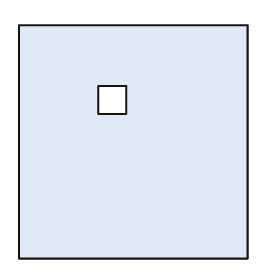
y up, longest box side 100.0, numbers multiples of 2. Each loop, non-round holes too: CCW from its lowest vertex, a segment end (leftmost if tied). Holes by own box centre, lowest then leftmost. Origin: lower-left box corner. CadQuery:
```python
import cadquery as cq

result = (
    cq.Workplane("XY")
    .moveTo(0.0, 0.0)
    .lineTo(98.0, 0.0)
    .lineTo(98.0, 100.0)
    .lineTo(0.0, 100.0)
    .close()
    .moveTo(34.0, 62.0)
    .lineTo(46.0, 62.0)
    .lineTo(46.0, 74.0)
    .lineTo(34.0, 74.0)
    .close()
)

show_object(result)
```